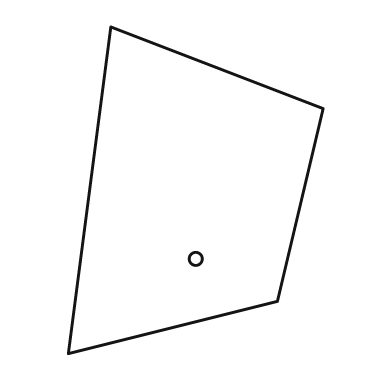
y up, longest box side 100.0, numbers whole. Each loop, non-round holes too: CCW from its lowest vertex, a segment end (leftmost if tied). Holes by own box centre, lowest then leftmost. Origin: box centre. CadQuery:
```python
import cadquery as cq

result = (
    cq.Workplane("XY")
    .moveTo(-39.0, -50.0)
    .lineTo(25.0, -34.0)
    .lineTo(39.0, 25.0)
    .lineTo(-26.0, 50.0)
    .close()
    .moveTo(0.0, -21.0)
    .circle(2.0)
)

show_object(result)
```